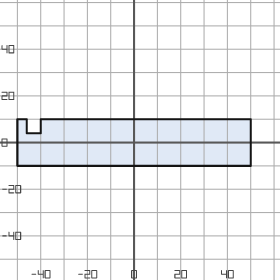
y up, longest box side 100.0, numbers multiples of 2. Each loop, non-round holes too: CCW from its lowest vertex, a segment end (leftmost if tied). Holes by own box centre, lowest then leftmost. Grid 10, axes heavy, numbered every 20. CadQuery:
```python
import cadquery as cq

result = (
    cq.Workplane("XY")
    .moveTo(-50.0, -10.0)
    .lineTo(50.0, -10.0)
    .lineTo(50.0, 10.0)
    .lineTo(-40.0, 10.0)
    .lineTo(-40.0, 4.0)
    .lineTo(-46.0, 4.0)
    .lineTo(-46.0, 10.0)
    .lineTo(-50.0, 10.0)
    .close()
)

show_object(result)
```